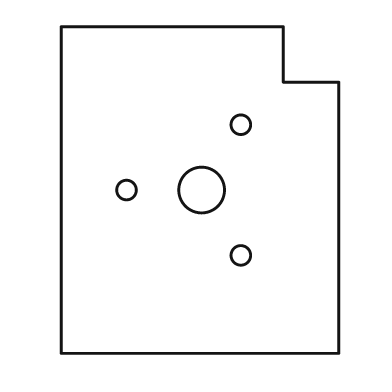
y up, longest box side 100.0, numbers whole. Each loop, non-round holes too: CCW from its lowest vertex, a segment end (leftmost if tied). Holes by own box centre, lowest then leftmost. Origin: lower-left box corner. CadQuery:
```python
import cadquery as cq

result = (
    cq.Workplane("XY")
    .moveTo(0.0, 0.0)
    .lineTo(85.0, 0.0)
    .lineTo(85.0, 83.0)
    .lineTo(68.0, 83.0)
    .lineTo(68.0, 100.0)
    .lineTo(0.0, 100.0)
    .close()
    .moveTo(55.0, 30.0)
    .circle(3.0)
    .moveTo(20.0, 50.0)
    .circle(3.0)
    .moveTo(43.0, 50.0)
    .circle(7.0)
    .moveTo(55.0, 70.0)
    .circle(3.0)
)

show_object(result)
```